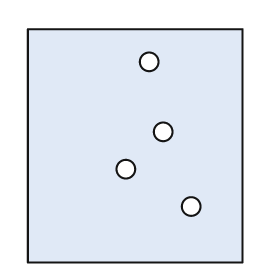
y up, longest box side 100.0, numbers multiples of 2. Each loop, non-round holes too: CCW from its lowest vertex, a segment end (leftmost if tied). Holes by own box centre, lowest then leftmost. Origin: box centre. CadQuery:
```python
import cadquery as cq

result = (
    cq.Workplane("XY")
    .moveTo(-46.0, -50.0)
    .lineTo(46.0, -50.0)
    .lineTo(46.0, 50.0)
    .lineTo(-46.0, 50.0)
    .close()
    .moveTo(24.0, -26.0)
    .circle(4.0)
    .moveTo(-4.0, -10.0)
    .circle(4.0)
    .moveTo(12.0, 6.0)
    .circle(4.0)
    .moveTo(6.0, 36.0)
    .circle(4.0)
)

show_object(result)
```